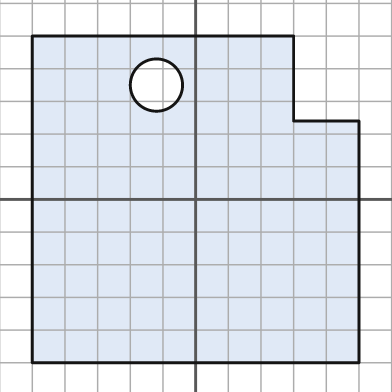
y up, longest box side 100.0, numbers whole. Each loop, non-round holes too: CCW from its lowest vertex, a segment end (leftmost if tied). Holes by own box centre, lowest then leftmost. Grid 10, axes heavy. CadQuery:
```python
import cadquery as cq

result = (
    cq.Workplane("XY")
    .moveTo(-50.0, -50.0)
    .lineTo(50.0, -50.0)
    .lineTo(50.0, 24.0)
    .lineTo(30.0, 24.0)
    .lineTo(30.0, 50.0)
    .lineTo(-50.0, 50.0)
    .close()
    .moveTo(-12.0, 35.0)
    .circle(8.0)
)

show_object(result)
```